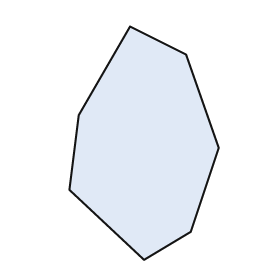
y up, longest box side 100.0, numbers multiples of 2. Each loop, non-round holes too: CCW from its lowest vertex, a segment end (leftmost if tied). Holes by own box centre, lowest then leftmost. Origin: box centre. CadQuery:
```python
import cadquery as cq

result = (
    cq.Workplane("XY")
    .moveTo(0.0, -50.0)
    .lineTo(20.0, -38.0)
    .lineTo(32.0, -2.0)
    .lineTo(18.0, 38.0)
    .lineTo(-6.0, 50.0)
    .lineTo(-28.0, 12.0)
    .lineTo(-32.0, -20.0)
    .close()
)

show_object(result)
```